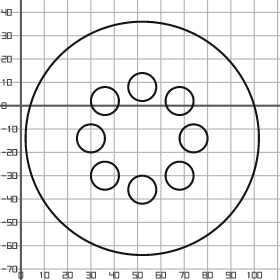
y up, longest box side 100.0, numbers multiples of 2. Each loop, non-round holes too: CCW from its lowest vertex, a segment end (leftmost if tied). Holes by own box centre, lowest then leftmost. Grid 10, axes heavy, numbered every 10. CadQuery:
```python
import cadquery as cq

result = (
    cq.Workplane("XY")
    .moveTo(52.0, -14.0)
    .circle(50.0)
    .moveTo(52.0, -36.0)
    .circle(6.0)
    .moveTo(36.0, -30.0)
    .circle(6.0)
    .moveTo(68.0, -30.0)
    .circle(6.0)
    .moveTo(30.0, -14.0)
    .circle(6.0)
    .moveTo(74.0, -14.0)
    .circle(6.0)
    .moveTo(36.0, 2.0)
    .circle(6.0)
    .moveTo(68.0, 2.0)
    .circle(6.0)
    .moveTo(52.0, 8.0)
    .circle(6.0)
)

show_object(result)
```